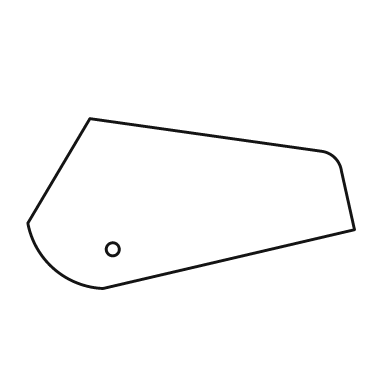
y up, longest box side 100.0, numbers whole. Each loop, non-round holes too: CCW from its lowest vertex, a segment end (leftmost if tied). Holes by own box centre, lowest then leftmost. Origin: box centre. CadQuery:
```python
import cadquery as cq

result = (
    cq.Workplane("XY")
    .moveTo(-27.0, -26.0)
    .lineTo(50.0, -8.0)
    .lineTo(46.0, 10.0)
    .threePointArc((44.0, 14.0), (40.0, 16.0))
    .lineTo(-31.0, 26.0)
    .lineTo(-50.0, -6.0)
    .threePointArc((-42.0, -20.0), (-27.0, -26.0))
    .close()
    .moveTo(-24.0, -14.0)
    .circle(2.0)
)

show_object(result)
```